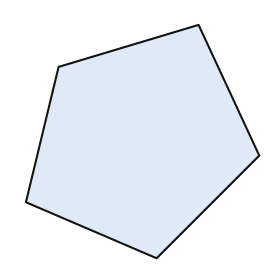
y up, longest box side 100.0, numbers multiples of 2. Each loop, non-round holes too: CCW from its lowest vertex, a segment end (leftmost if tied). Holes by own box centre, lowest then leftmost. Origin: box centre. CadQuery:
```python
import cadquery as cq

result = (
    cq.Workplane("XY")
    .moveTo(6.0, -50.0)
    .lineTo(50.0, -6.0)
    .lineTo(24.0, 50.0)
    .lineTo(-36.0, 32.0)
    .lineTo(-50.0, -26.0)
    .close()
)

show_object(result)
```